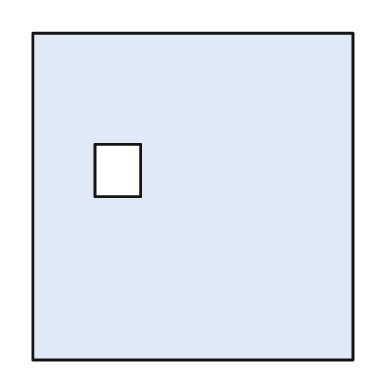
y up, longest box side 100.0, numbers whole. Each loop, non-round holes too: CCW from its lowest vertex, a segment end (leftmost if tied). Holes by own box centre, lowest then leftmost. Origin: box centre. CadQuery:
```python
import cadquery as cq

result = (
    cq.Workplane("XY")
    .moveTo(-49.0, -50.0)
    .lineTo(49.0, -50.0)
    .lineTo(49.0, 50.0)
    .lineTo(-49.0, 50.0)
    .close()
    .moveTo(-30.0, 0.0)
    .lineTo(-16.0, 0.0)
    .lineTo(-16.0, 16.0)
    .lineTo(-30.0, 16.0)
    .close()
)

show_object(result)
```